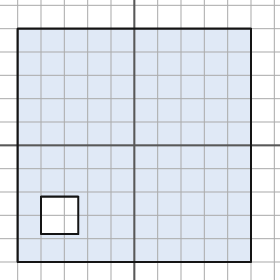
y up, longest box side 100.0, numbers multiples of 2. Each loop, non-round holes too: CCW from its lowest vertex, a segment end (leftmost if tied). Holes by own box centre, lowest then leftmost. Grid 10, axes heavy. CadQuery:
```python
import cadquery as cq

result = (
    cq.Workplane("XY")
    .moveTo(-50.0, -50.0)
    .lineTo(50.0, -50.0)
    .lineTo(50.0, 50.0)
    .lineTo(-50.0, 50.0)
    .close()
    .moveTo(-40.0, -38.0)
    .lineTo(-24.0, -38.0)
    .lineTo(-24.0, -22.0)
    .lineTo(-40.0, -22.0)
    .close()
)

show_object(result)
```